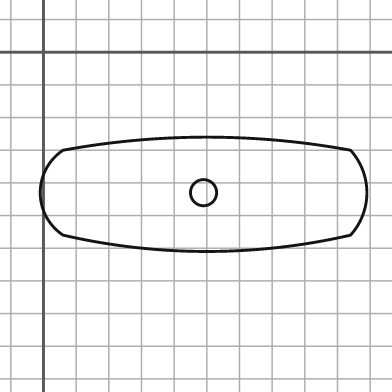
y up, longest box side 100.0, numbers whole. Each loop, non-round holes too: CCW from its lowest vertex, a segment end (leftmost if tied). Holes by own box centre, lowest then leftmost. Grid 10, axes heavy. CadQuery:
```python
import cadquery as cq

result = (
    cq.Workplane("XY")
    .moveTo(6.0, -56.0)
    .threePointArc((50.0, -61.0), (94.0, -56.0))
    .threePointArc((99.0, -43.0), (94.0, -30.0))
    .threePointArc((50.0, -26.0), (6.0, -30.0))
    .threePointArc((-1.0, -43.0), (6.0, -56.0))
    .close()
    .moveTo(49.0, -43.0)
    .circle(4.0)
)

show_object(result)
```